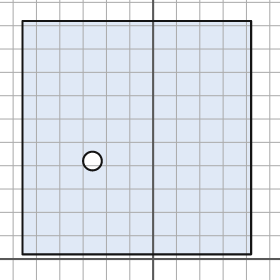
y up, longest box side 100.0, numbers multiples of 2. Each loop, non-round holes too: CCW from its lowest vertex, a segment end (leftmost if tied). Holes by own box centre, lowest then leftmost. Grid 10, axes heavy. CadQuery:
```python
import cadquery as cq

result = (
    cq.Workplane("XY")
    .moveTo(-56.0, 2.0)
    .lineTo(42.0, 2.0)
    .lineTo(42.0, 102.0)
    .lineTo(-56.0, 102.0)
    .close()
    .moveTo(-26.0, 42.0)
    .circle(4.0)
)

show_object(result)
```